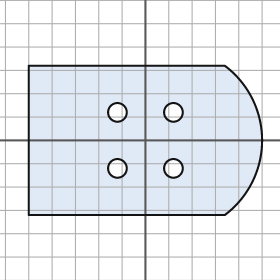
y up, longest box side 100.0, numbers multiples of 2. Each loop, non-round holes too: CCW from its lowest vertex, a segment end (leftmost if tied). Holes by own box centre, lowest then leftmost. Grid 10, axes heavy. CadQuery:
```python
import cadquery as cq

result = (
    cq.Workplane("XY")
    .moveTo(-50.0, -32.0)
    .lineTo(34.0, -32.0)
    .threePointArc((50.0, 0.0), (34.0, 32.0))
    .lineTo(-50.0, 32.0)
    .close()
    .moveTo(-12.0, -12.0)
    .circle(4.0)
    .moveTo(12.0, -12.0)
    .circle(4.0)
    .moveTo(-12.0, 12.0)
    .circle(4.0)
    .moveTo(12.0, 12.0)
    .circle(4.0)
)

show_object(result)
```